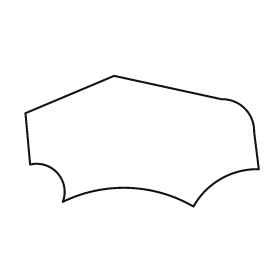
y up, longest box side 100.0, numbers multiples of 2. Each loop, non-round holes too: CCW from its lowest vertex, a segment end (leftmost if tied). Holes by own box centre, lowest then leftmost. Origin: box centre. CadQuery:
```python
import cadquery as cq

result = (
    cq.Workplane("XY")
    .moveTo(22.0, -28.0)
    .threePointArc((34.0, -16.0), (50.0, -12.0))
    .lineTo(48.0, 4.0)
    .threePointArc((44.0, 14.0), (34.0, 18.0))
    .lineTo(-12.0, 28.0)
    .lineTo(-50.0, 12.0)
    .lineTo(-48.0, -10.0)
    .threePointArc((-36.0, -14.0), (-34.0, -26.0))
    .threePointArc((-6.0, -20.0), (22.0, -28.0))
    .close()
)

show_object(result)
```